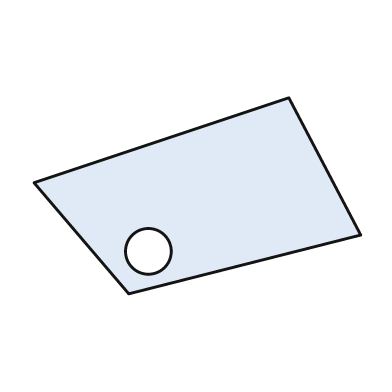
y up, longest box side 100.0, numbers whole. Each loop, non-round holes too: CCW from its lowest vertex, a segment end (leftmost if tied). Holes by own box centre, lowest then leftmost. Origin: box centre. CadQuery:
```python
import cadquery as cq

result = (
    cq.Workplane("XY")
    .moveTo(-21.0, -30.0)
    .lineTo(50.0, -12.0)
    .lineTo(28.0, 30.0)
    .lineTo(-50.0, 4.0)
    .close()
    .moveTo(-15.0, -17.0)
    .circle(7.0)
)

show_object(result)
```